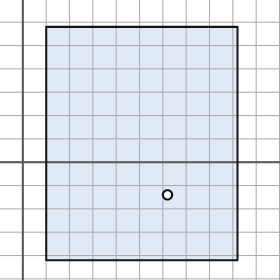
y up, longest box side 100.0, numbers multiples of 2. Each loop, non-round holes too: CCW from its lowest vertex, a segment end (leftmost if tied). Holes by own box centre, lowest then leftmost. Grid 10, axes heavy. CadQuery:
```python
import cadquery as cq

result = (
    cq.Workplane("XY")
    .moveTo(10.0, -42.0)
    .lineTo(92.0, -42.0)
    .lineTo(92.0, 58.0)
    .lineTo(10.0, 58.0)
    .close()
    .moveTo(62.0, -14.0)
    .circle(2.0)
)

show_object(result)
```